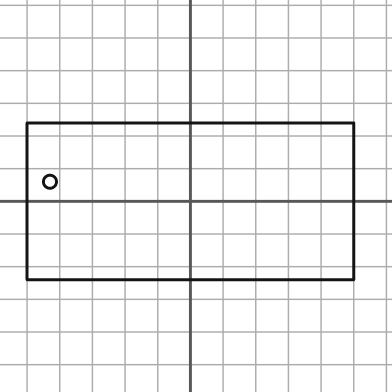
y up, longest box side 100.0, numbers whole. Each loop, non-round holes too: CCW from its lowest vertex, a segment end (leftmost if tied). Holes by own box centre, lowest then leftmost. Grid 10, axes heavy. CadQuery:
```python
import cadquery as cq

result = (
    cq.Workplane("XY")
    .moveTo(-50.0, -24.0)
    .lineTo(50.0, -24.0)
    .lineTo(50.0, 24.0)
    .lineTo(-50.0, 24.0)
    .close()
    .moveTo(-43.0, 6.0)
    .circle(2.0)
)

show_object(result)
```